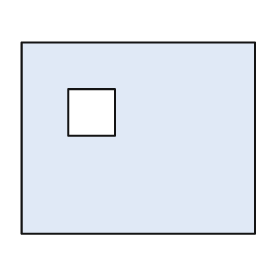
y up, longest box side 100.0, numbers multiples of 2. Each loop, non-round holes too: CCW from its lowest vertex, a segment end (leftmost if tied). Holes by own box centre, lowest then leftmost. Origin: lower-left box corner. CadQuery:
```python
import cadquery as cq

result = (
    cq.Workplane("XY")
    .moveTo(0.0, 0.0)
    .lineTo(100.0, 0.0)
    .lineTo(100.0, 82.0)
    .lineTo(0.0, 82.0)
    .close()
    .moveTo(20.0, 42.0)
    .lineTo(40.0, 42.0)
    .lineTo(40.0, 62.0)
    .lineTo(20.0, 62.0)
    .close()
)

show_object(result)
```